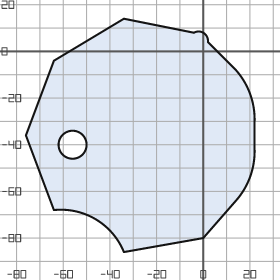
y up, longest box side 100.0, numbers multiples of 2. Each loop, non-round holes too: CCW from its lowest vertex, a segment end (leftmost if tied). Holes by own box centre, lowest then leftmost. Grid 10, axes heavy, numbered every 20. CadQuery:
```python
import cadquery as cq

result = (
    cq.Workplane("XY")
    .moveTo(-34.0, -86.0)
    .lineTo(0.0, -80.0)
    .lineTo(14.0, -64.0)
    .threePointArc((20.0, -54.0), (22.0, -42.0))
    .lineTo(22.0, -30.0)
    .threePointArc((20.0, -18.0), (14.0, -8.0))
    .lineTo(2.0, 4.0)
    .threePointArc((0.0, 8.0), (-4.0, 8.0))
    .lineTo(-34.0, 14.0)
    .lineTo(-64.0, -4.0)
    .lineTo(-76.0, -36.0)
    .lineTo(-64.0, -68.0)
    .threePointArc((-46.0, -72.0), (-34.0, -86.0))
    .close()
    .moveTo(-56.0, -40.0)
    .circle(6.0)
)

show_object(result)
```